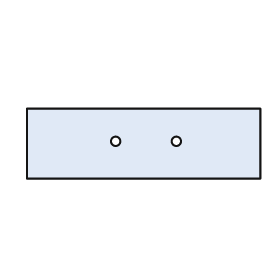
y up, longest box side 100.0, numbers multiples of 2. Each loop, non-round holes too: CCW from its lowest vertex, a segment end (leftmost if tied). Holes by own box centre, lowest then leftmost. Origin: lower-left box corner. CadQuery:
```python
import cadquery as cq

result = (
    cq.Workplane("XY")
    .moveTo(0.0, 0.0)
    .lineTo(100.0, 0.0)
    .lineTo(100.0, 30.0)
    .lineTo(0.0, 30.0)
    .close()
    .moveTo(38.0, 16.0)
    .circle(2.0)
    .moveTo(64.0, 16.0)
    .circle(2.0)
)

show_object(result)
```